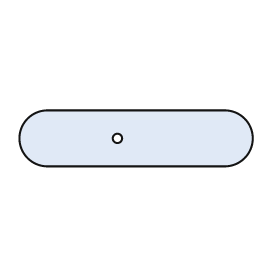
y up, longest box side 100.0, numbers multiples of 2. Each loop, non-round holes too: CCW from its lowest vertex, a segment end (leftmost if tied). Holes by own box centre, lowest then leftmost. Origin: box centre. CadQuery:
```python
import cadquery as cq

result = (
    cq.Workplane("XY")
    .moveTo(-38.0, -12.0)
    .lineTo(38.0, -12.0)
    .threePointArc((50.0, 0.0), (38.0, 12.0))
    .lineTo(-38.0, 12.0)
    .threePointArc((-50.0, 0.0), (-38.0, -12.0))
    .close()
    .moveTo(-8.0, 0.0)
    .circle(2.0)
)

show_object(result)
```